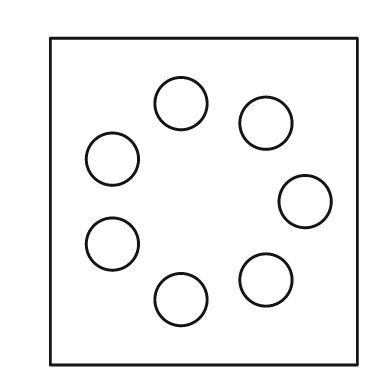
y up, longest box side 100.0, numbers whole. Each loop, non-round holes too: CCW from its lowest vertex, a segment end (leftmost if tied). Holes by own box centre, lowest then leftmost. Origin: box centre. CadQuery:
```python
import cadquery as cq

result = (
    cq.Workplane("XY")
    .moveTo(-47.0, -50.0)
    .lineTo(47.0, -50.0)
    .lineTo(47.0, 50.0)
    .lineTo(-47.0, 50.0)
    .close()
    .moveTo(-7.0, -30.0)
    .circle(8.0)
    .moveTo(19.0, -24.0)
    .circle(8.0)
    .moveTo(-28.0, -13.0)
    .circle(8.0)
    .moveTo(31.0, 0.0)
    .circle(8.0)
    .moveTo(-28.0, 13.0)
    .circle(8.0)
    .moveTo(19.0, 24.0)
    .circle(8.0)
    .moveTo(-7.0, 30.0)
    .circle(8.0)
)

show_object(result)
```